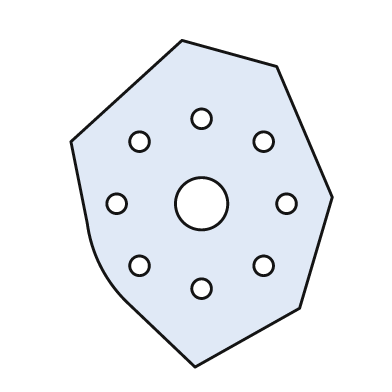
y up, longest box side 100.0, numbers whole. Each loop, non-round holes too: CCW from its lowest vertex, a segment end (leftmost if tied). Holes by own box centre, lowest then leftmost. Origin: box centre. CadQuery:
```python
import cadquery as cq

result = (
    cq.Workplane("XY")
    .moveTo(-2.0, -50.0)
    .lineTo(30.0, -32.0)
    .lineTo(40.0, 2.0)
    .lineTo(23.0, 42.0)
    .lineTo(-6.0, 50.0)
    .lineTo(-40.0, 19.0)
    .lineTo(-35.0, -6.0)
    .threePointArc((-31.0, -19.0), (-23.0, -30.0))
    .close()
    .moveTo(0.0, -26.0)
    .circle(3.0)
    .moveTo(-19.0, -19.0)
    .circle(3.0)
    .moveTo(19.0, -19.0)
    .circle(3.0)
    .moveTo(-26.0, 0.0)
    .circle(3.0)
    .moveTo(0.0, 0.0)
    .circle(8.0)
    .moveTo(26.0, 0.0)
    .circle(3.0)
    .moveTo(-19.0, 19.0)
    .circle(3.0)
    .moveTo(19.0, 19.0)
    .circle(3.0)
    .moveTo(0.0, 26.0)
    .circle(3.0)
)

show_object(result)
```